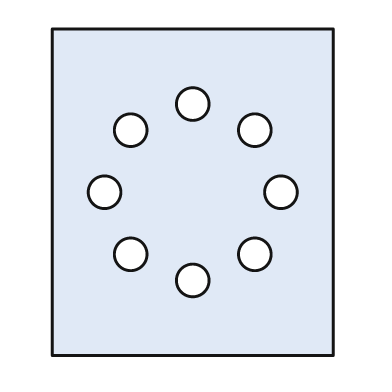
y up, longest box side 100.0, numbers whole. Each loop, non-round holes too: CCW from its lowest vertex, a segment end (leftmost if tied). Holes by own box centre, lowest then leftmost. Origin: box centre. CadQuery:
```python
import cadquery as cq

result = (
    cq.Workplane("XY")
    .moveTo(-43.0, -50.0)
    .lineTo(43.0, -50.0)
    .lineTo(43.0, 50.0)
    .lineTo(-43.0, 50.0)
    .close()
    .moveTo(0.0, -27.0)
    .circle(5.0)
    .moveTo(-19.0, -19.0)
    .circle(5.0)
    .moveTo(19.0, -19.0)
    .circle(5.0)
    .moveTo(-27.0, 0.0)
    .circle(5.0)
    .moveTo(27.0, 0.0)
    .circle(5.0)
    .moveTo(-19.0, 19.0)
    .circle(5.0)
    .moveTo(19.0, 19.0)
    .circle(5.0)
    .moveTo(0.0, 27.0)
    .circle(5.0)
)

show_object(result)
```